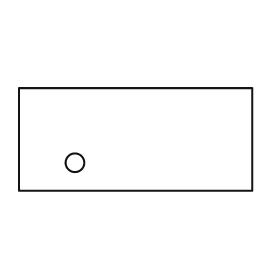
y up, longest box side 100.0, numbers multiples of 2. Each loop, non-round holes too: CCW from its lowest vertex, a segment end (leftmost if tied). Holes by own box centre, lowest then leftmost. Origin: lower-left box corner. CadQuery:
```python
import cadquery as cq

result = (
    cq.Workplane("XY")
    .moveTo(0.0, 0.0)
    .lineTo(100.0, 0.0)
    .lineTo(100.0, 44.0)
    .lineTo(0.0, 44.0)
    .close()
    .moveTo(24.0, 12.0)
    .circle(4.0)
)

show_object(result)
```